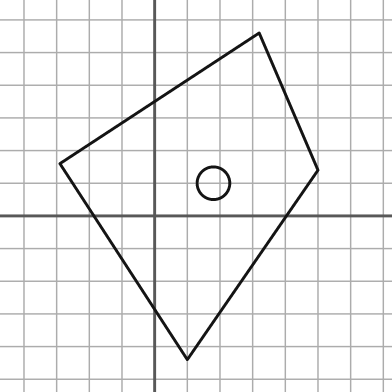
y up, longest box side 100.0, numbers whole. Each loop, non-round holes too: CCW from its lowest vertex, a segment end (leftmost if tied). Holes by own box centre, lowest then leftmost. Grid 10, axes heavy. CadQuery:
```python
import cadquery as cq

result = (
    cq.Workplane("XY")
    .moveTo(10.0, -44.0)
    .lineTo(50.0, 14.0)
    .lineTo(32.0, 56.0)
    .lineTo(-29.0, 16.0)
    .close()
    .moveTo(18.0, 10.0)
    .circle(5.0)
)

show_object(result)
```